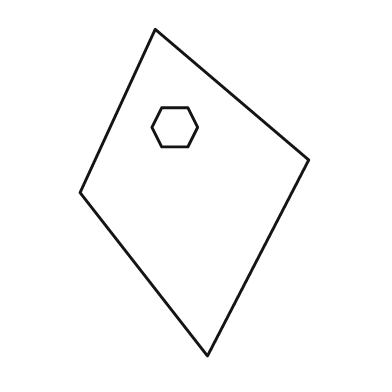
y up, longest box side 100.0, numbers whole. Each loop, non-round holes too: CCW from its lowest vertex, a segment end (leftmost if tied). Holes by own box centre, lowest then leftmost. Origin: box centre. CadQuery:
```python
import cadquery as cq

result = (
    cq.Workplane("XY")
    .moveTo(4.0, -50.0)
    .lineTo(35.0, 10.0)
    .lineTo(-12.0, 50.0)
    .lineTo(-35.0, 0.0)
    .close()
    .moveTo(-10.0, 14.0)
    .lineTo(-2.0, 14.0)
    .lineTo(1.0, 20.0)
    .lineTo(-2.0, 26.0)
    .lineTo(-10.0, 26.0)
    .lineTo(-13.0, 20.0)
    .close()
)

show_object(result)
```